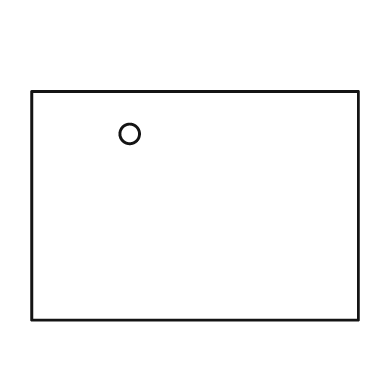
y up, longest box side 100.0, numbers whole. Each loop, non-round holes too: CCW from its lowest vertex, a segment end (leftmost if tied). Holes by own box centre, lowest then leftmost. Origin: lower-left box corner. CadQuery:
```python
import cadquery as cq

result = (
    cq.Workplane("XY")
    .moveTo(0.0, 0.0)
    .lineTo(100.0, 0.0)
    .lineTo(100.0, 70.0)
    .lineTo(0.0, 70.0)
    .close()
    .moveTo(30.0, 57.0)
    .circle(3.0)
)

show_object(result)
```